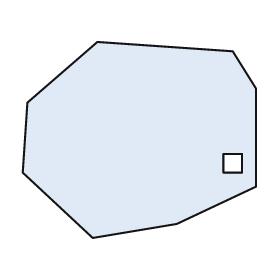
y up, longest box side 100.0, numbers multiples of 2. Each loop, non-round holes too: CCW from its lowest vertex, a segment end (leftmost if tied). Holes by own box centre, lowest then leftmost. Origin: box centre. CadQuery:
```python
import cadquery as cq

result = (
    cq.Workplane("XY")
    .moveTo(-20.0, -42.0)
    .lineTo(16.0, -36.0)
    .lineTo(50.0, -20.0)
    .lineTo(50.0, 22.0)
    .lineTo(40.0, 38.0)
    .lineTo(-18.0, 42.0)
    .lineTo(-48.0, 16.0)
    .lineTo(-50.0, -14.0)
    .close()
    .moveTo(36.0, -14.0)
    .lineTo(44.0, -14.0)
    .lineTo(44.0, -6.0)
    .lineTo(36.0, -6.0)
    .close()
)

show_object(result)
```